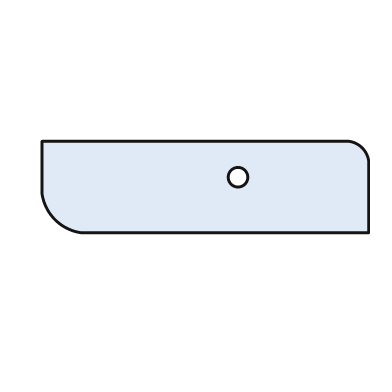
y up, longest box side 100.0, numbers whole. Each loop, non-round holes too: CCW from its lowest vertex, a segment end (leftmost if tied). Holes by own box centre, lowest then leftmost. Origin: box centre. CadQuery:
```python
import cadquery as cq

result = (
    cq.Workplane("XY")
    .moveTo(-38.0, -14.0)
    .lineTo(50.0, -14.0)
    .lineTo(50.0, 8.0)
    .threePointArc((48.0, 12.0), (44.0, 14.0))
    .lineTo(-50.0, 14.0)
    .lineTo(-50.0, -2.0)
    .threePointArc((-46.0, -10.0), (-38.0, -14.0))
    .close()
    .moveTo(10.0, 3.0)
    .circle(3.0)
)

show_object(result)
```